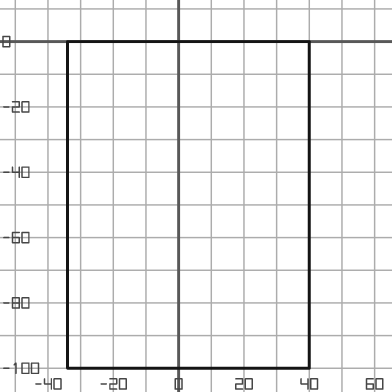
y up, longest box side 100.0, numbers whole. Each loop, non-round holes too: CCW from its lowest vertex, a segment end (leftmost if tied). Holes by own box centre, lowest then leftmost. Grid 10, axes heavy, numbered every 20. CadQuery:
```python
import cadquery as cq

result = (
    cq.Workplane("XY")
    .moveTo(-34.0, -100.0)
    .lineTo(40.0, -100.0)
    .lineTo(40.0, 0.0)
    .lineTo(-34.0, 0.0)
    .close()
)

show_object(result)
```